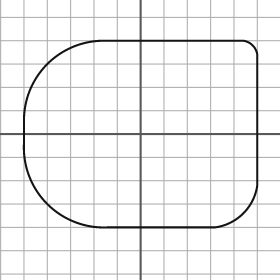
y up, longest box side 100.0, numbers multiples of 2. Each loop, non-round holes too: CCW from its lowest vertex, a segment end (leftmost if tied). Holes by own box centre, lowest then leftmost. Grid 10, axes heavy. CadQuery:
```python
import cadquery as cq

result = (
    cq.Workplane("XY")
    .moveTo(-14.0, -40.0)
    .lineTo(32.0, -40.0)
    .threePointArc((44.0, -34.0), (50.0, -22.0))
    .lineTo(50.0, 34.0)
    .threePointArc((48.0, 38.0), (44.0, 40.0))
    .lineTo(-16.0, 40.0)
    .threePointArc((-40.0, 30.0), (-50.0, 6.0))
    .lineTo(-50.0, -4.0)
    .threePointArc((-40.0, -30.0), (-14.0, -40.0))
    .close()
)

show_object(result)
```